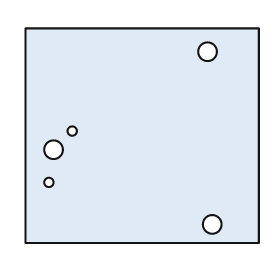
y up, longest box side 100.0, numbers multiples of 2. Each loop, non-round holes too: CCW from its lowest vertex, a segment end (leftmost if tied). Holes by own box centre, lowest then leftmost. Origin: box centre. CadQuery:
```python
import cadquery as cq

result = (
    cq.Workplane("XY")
    .moveTo(-50.0, -46.0)
    .lineTo(50.0, -46.0)
    .lineTo(50.0, 46.0)
    .lineTo(-50.0, 46.0)
    .close()
    .moveTo(30.0, -38.0)
    .circle(4.0)
    .moveTo(-40.0, -20.0)
    .circle(2.0)
    .moveTo(-38.0, -6.0)
    .circle(4.0)
    .moveTo(-30.0, 2.0)
    .circle(2.0)
    .moveTo(28.0, 36.0)
    .circle(4.0)
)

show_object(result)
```